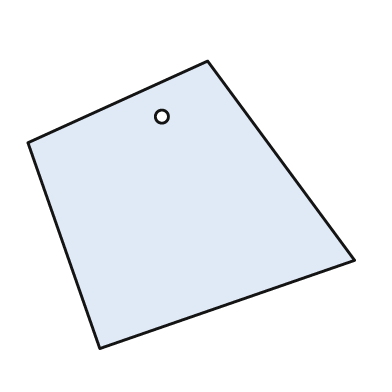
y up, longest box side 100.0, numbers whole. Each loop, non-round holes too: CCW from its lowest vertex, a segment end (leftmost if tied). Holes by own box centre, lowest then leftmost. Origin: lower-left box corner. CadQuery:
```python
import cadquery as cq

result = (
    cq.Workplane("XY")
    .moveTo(22.0, 0.0)
    .lineTo(100.0, 27.0)
    .lineTo(55.0, 88.0)
    .lineTo(0.0, 63.0)
    .close()
    .moveTo(41.0, 71.0)
    .circle(2.0)
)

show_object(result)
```